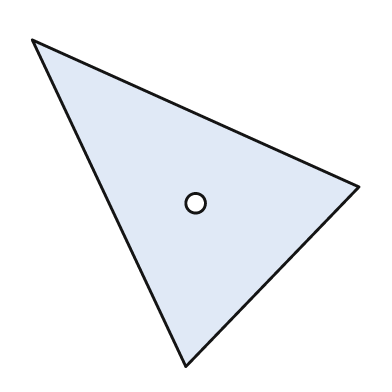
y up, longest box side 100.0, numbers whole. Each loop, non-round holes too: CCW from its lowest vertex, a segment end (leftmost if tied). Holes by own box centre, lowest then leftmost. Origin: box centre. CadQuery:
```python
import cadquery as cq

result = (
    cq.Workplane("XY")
    .moveTo(-3.0, -50.0)
    .lineTo(50.0, 5.0)
    .lineTo(-50.0, 50.0)
    .close()
    .moveTo(0.0, 0.0)
    .circle(3.0)
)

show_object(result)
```